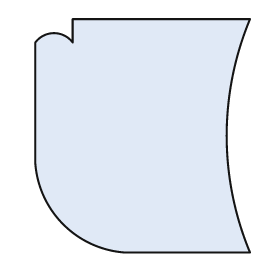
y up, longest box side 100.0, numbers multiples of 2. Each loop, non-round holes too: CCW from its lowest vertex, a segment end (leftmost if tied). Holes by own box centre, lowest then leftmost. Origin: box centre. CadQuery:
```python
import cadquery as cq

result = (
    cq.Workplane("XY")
    .moveTo(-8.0, -50.0)
    .lineTo(46.0, -50.0)
    .threePointArc((36.0, 0.0), (46.0, 50.0))
    .lineTo(-30.0, 50.0)
    .lineTo(-30.0, 40.0)
    .threePointArc((-38.0, 44.0), (-46.0, 40.0))
    .lineTo(-46.0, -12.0)
    .threePointArc((-34.0, -38.0), (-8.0, -50.0))
    .close()
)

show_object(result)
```